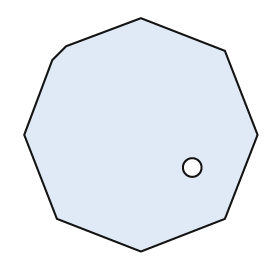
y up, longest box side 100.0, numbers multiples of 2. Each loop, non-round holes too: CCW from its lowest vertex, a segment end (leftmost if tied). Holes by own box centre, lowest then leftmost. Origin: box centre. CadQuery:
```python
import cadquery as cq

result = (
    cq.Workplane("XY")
    .moveTo(0.0, -50.0)
    .lineTo(36.0, -36.0)
    .lineTo(50.0, 0.0)
    .lineTo(36.0, 36.0)
    .lineTo(0.0, 50.0)
    .lineTo(-32.0, 38.0)
    .lineTo(-38.0, 32.0)
    .lineTo(-50.0, 0.0)
    .lineTo(-36.0, -36.0)
    .close()
    .moveTo(22.0, -14.0)
    .circle(4.0)
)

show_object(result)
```